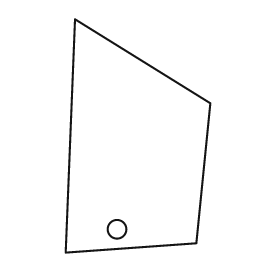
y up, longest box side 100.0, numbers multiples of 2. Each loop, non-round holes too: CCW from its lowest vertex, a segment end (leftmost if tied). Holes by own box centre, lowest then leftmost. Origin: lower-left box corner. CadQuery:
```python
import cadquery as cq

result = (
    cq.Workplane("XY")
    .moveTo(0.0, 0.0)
    .lineTo(56.0, 4.0)
    .lineTo(62.0, 64.0)
    .lineTo(4.0, 100.0)
    .close()
    .moveTo(22.0, 10.0)
    .circle(4.0)
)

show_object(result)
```